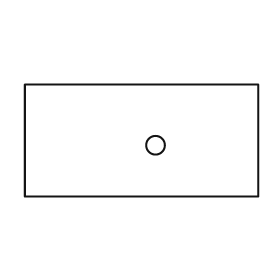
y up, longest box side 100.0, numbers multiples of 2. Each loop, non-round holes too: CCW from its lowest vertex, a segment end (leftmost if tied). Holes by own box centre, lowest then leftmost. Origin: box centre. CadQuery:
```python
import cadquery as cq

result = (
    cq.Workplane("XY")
    .moveTo(-50.0, -24.0)
    .lineTo(50.0, -24.0)
    .lineTo(50.0, 24.0)
    .lineTo(-50.0, 24.0)
    .close()
    .moveTo(6.0, -2.0)
    .circle(4.0)
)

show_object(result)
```